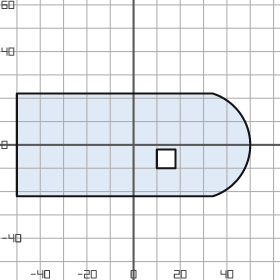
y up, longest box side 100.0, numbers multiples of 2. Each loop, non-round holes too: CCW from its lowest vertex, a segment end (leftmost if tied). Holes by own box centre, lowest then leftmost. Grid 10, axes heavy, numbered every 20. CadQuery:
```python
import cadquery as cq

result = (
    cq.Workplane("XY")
    .moveTo(-50.0, -22.0)
    .lineTo(34.0, -22.0)
    .threePointArc((50.0, 0.0), (34.0, 22.0))
    .lineTo(-50.0, 22.0)
    .close()
    .moveTo(10.0, -10.0)
    .lineTo(18.0, -10.0)
    .lineTo(18.0, -2.0)
    .lineTo(10.0, -2.0)
    .close()
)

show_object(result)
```